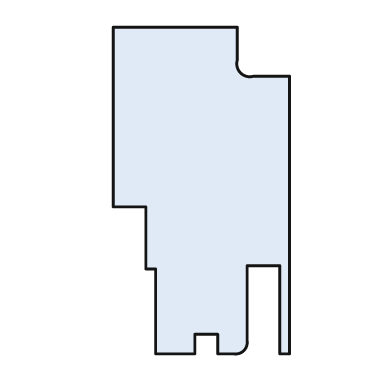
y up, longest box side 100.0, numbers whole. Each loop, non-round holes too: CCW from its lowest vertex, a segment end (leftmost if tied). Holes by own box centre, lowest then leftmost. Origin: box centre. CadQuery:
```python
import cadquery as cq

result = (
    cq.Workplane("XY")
    .moveTo(-14.0, -50.0)
    .lineTo(-2.0, -50.0)
    .lineTo(-2.0, -44.0)
    .lineTo(5.0, -44.0)
    .lineTo(5.0, -50.0)
    .lineTo(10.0, -50.0)
    .threePointArc((13.0, -49.0), (14.0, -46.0))
    .lineTo(14.0, -23.0)
    .lineTo(24.0, -23.0)
    .lineTo(24.0, -50.0)
    .lineTo(27.0, -50.0)
    .lineTo(27.0, 35.0)
    .lineTo(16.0, 35.0)
    .threePointArc((12.0, 36.0), (11.0, 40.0))
    .lineTo(11.0, 50.0)
    .lineTo(-27.0, 50.0)
    .lineTo(-27.0, -5.0)
    .lineTo(-17.0, -5.0)
    .lineTo(-17.0, -24.0)
    .lineTo(-14.0, -24.0)
    .close()
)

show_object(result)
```